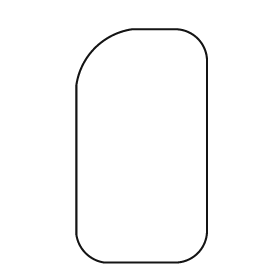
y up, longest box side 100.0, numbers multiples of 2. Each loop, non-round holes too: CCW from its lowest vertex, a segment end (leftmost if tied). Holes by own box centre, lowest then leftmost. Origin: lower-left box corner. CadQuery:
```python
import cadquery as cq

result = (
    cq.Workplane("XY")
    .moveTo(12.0, 0.0)
    .lineTo(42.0, 0.0)
    .threePointArc((52.0, 4.0), (56.0, 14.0))
    .lineTo(56.0, 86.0)
    .threePointArc((52.0, 96.0), (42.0, 100.0))
    .lineTo(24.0, 100.0)
    .threePointArc((8.0, 92.0), (0.0, 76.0))
    .lineTo(0.0, 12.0)
    .threePointArc((4.0, 4.0), (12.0, 0.0))
    .close()
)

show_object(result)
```